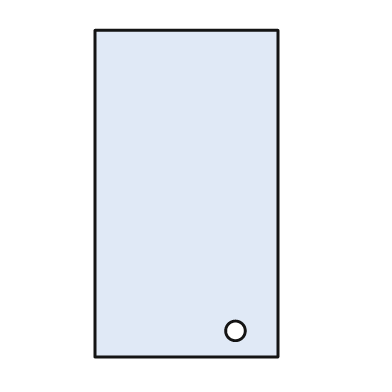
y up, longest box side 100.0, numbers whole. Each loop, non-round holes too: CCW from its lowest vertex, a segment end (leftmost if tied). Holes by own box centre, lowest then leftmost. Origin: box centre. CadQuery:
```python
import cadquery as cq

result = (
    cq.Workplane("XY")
    .moveTo(-28.0, -50.0)
    .lineTo(28.0, -50.0)
    .lineTo(28.0, 50.0)
    .lineTo(-28.0, 50.0)
    .close()
    .moveTo(15.0, -42.0)
    .circle(3.0)
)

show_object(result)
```